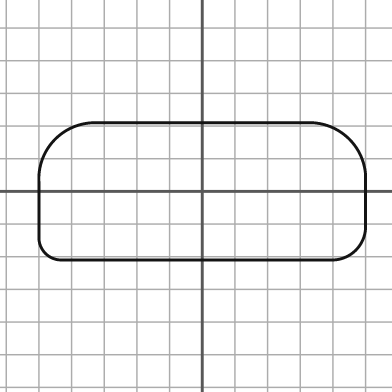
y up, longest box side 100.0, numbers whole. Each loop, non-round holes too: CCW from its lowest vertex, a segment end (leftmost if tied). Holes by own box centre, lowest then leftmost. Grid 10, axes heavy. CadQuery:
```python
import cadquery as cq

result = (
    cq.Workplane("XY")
    .moveTo(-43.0, -21.0)
    .lineTo(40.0, -21.0)
    .threePointArc((47.0, -18.0), (50.0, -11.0))
    .lineTo(50.0, 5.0)
    .threePointArc((45.0, 16.0), (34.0, 21.0))
    .lineTo(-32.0, 21.0)
    .threePointArc((-45.0, 16.0), (-50.0, 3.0))
    .lineTo(-50.0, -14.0)
    .threePointArc((-48.0, -19.0), (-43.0, -21.0))
    .close()
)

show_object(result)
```